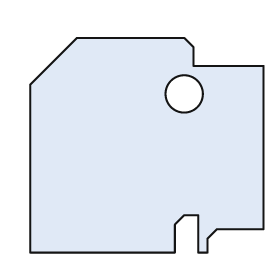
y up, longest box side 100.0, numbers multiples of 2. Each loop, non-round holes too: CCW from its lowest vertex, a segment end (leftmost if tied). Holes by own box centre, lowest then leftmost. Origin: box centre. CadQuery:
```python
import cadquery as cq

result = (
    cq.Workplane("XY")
    .moveTo(-50.0, -46.0)
    .lineTo(12.0, -46.0)
    .lineTo(12.0, -34.0)
    .lineTo(16.0, -30.0)
    .lineTo(22.0, -30.0)
    .lineTo(22.0, -46.0)
    .lineTo(26.0, -46.0)
    .lineTo(26.0, -40.0)
    .lineTo(30.0, -36.0)
    .lineTo(50.0, -36.0)
    .lineTo(50.0, 34.0)
    .lineTo(20.0, 34.0)
    .lineTo(20.0, 42.0)
    .lineTo(16.0, 46.0)
    .lineTo(-30.0, 46.0)
    .lineTo(-50.0, 26.0)
    .close()
    .moveTo(16.0, 22.0)
    .circle(8.0)
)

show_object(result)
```